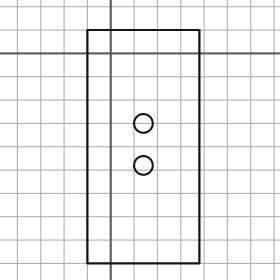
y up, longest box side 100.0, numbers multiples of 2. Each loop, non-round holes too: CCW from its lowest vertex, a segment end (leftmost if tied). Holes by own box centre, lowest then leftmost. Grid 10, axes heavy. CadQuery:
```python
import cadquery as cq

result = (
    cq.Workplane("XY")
    .moveTo(-10.0, -90.0)
    .lineTo(38.0, -90.0)
    .lineTo(38.0, 10.0)
    .lineTo(-10.0, 10.0)
    .close()
    .moveTo(14.0, -48.0)
    .circle(4.0)
    .moveTo(14.0, -30.0)
    .circle(4.0)
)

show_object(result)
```